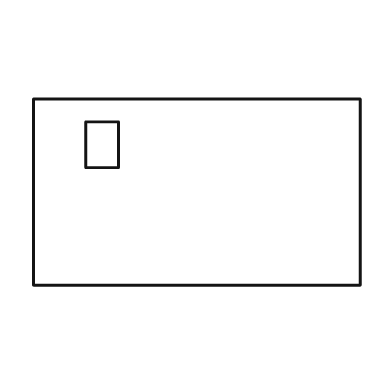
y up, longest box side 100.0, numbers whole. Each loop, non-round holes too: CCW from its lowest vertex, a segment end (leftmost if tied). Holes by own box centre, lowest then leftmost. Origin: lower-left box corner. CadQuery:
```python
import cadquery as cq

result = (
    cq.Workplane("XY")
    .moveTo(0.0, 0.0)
    .lineTo(100.0, 0.0)
    .lineTo(100.0, 57.0)
    .lineTo(0.0, 57.0)
    .close()
    .moveTo(16.0, 36.0)
    .lineTo(26.0, 36.0)
    .lineTo(26.0, 50.0)
    .lineTo(16.0, 50.0)
    .close()
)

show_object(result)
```